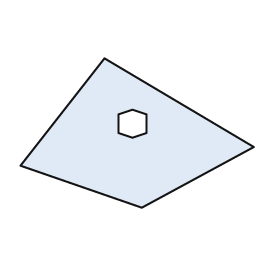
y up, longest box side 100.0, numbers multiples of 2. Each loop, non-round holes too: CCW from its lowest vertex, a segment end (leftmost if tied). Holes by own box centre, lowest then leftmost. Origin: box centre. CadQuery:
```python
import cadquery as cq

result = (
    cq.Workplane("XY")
    .moveTo(2.0, -32.0)
    .lineTo(50.0, -6.0)
    .lineTo(-14.0, 32.0)
    .lineTo(-50.0, -14.0)
    .close()
    .moveTo(-2.0, -2.0)
    .lineTo(4.0, 0.0)
    .lineTo(4.0, 8.0)
    .lineTo(-2.0, 10.0)
    .lineTo(-8.0, 8.0)
    .lineTo(-8.0, 0.0)
    .close()
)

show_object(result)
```